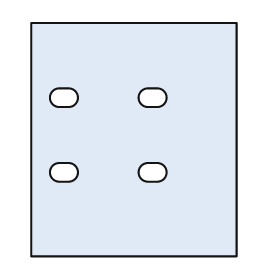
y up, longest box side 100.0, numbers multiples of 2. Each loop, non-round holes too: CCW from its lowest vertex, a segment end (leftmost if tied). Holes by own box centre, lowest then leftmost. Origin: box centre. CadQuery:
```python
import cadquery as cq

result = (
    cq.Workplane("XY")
    .moveTo(-44.0, -50.0)
    .lineTo(44.0, -50.0)
    .lineTo(44.0, 50.0)
    .lineTo(-44.0, 50.0)
    .close()
    .moveTo(-32.0, -18.0)
    .lineTo(-28.0, -18.0)
    .threePointArc((-24.0, -14.0), (-28.0, -10.0))
    .lineTo(-32.0, -10.0)
    .threePointArc((-36.0, -14.0), (-32.0, -18.0))
    .close()
    .moveTo(6.0, -18.0)
    .lineTo(10.0, -18.0)
    .threePointArc((14.0, -14.0), (10.0, -10.0))
    .lineTo(6.0, -10.0)
    .threePointArc((2.0, -14.0), (6.0, -18.0))
    .close()
    .moveTo(-32.0, 14.0)
    .lineTo(-28.0, 14.0)
    .threePointArc((-24.0, 18.0), (-28.0, 22.0))
    .lineTo(-32.0, 22.0)
    .threePointArc((-36.0, 18.0), (-32.0, 14.0))
    .close()
    .moveTo(6.0, 14.0)
    .lineTo(10.0, 14.0)
    .threePointArc((14.0, 18.0), (10.0, 22.0))
    .lineTo(6.0, 22.0)
    .threePointArc((2.0, 18.0), (6.0, 14.0))
    .close()
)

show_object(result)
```